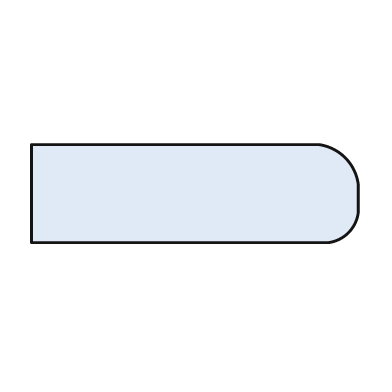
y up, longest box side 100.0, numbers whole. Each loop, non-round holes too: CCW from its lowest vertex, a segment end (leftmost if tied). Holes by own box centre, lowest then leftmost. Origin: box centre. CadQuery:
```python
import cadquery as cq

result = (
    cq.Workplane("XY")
    .moveTo(-50.0, -15.0)
    .lineTo(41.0, -15.0)
    .threePointArc((47.0, -12.0), (50.0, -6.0))
    .lineTo(50.0, 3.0)
    .threePointArc((46.0, 11.0), (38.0, 15.0))
    .lineTo(-50.0, 15.0)
    .close()
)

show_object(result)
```